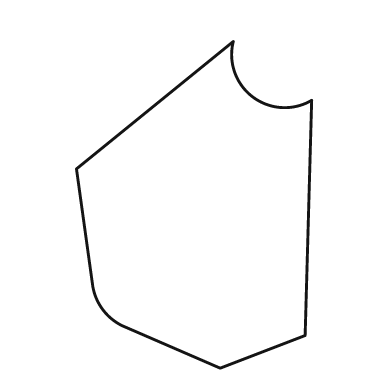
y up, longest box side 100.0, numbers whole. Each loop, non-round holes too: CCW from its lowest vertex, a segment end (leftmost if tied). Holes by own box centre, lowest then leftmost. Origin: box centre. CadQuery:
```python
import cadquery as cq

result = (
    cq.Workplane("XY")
    .moveTo(8.0, -50.0)
    .lineTo(34.0, -40.0)
    .lineTo(36.0, 32.0)
    .threePointArc((18.0, 33.0), (12.0, 50.0))
    .lineTo(-36.0, 11.0)
    .lineTo(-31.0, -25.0)
    .threePointArc((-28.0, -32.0), (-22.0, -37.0))
    .close()
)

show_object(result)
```